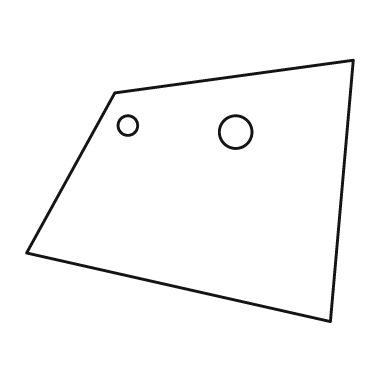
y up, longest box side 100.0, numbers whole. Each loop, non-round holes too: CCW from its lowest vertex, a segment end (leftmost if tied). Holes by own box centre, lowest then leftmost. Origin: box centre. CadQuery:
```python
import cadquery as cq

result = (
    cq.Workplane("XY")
    .moveTo(43.0, -40.0)
    .lineTo(50.0, 40.0)
    .lineTo(-23.0, 30.0)
    .lineTo(-50.0, -19.0)
    .close()
    .moveTo(14.0, 18.0)
    .circle(5.0)
    .moveTo(-19.0, 20.0)
    .circle(3.0)
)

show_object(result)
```